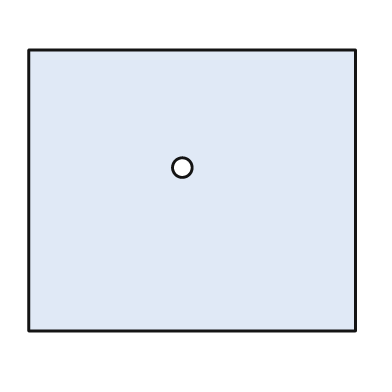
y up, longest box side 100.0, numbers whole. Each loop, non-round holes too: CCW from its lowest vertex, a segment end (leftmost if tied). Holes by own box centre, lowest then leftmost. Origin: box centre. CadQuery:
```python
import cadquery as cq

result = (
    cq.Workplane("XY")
    .moveTo(-50.0, -43.0)
    .lineTo(50.0, -43.0)
    .lineTo(50.0, 43.0)
    .lineTo(-50.0, 43.0)
    .close()
    .moveTo(-3.0, 7.0)
    .circle(3.0)
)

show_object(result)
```